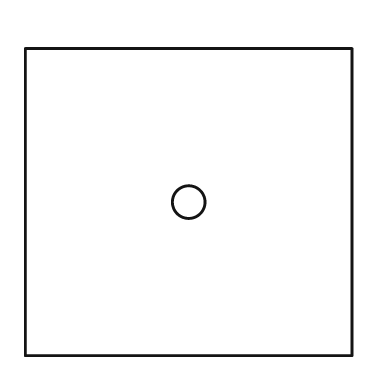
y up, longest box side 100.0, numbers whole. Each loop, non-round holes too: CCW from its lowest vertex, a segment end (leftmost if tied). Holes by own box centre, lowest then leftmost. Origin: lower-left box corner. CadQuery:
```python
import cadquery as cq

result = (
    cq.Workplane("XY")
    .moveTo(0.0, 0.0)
    .lineTo(100.0, 0.0)
    .lineTo(100.0, 94.0)
    .lineTo(0.0, 94.0)
    .close()
    .moveTo(50.0, 47.0)
    .circle(5.0)
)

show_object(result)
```